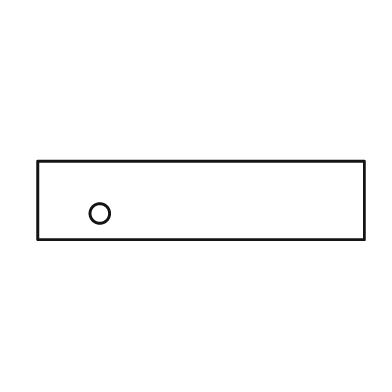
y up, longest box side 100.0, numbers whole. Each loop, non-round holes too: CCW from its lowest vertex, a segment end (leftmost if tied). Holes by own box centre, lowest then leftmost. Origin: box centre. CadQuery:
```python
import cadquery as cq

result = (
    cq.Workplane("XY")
    .moveTo(-50.0, -12.0)
    .lineTo(50.0, -12.0)
    .lineTo(50.0, 12.0)
    .lineTo(-50.0, 12.0)
    .close()
    .moveTo(-31.0, -4.0)
    .circle(3.0)
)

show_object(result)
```